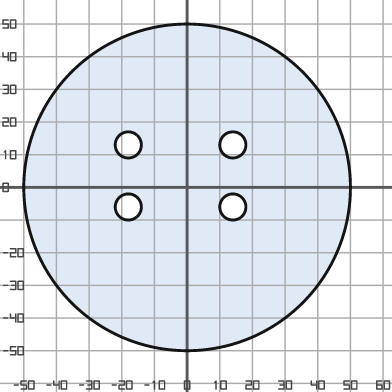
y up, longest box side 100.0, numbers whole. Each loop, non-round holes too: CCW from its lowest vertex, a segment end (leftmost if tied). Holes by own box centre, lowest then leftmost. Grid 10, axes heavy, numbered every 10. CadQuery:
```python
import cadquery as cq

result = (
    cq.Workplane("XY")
    .moveTo(0.0, 0.0)
    .circle(50.0)
    .moveTo(-18.0, -6.0)
    .circle(4.0)
    .moveTo(14.0, -6.0)
    .circle(4.0)
    .moveTo(-18.0, 13.0)
    .circle(4.0)
    .moveTo(14.0, 13.0)
    .circle(4.0)
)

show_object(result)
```